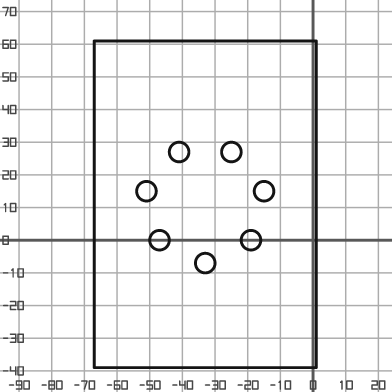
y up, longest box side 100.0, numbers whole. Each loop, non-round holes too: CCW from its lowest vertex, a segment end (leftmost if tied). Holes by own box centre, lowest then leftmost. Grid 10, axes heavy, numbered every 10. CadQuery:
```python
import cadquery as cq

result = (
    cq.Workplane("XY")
    .moveTo(-67.0, -39.0)
    .lineTo(1.0, -39.0)
    .lineTo(1.0, 61.0)
    .lineTo(-67.0, 61.0)
    .close()
    .moveTo(-33.0, -7.0)
    .circle(3.0)
    .moveTo(-47.0, 0.0)
    .circle(3.0)
    .moveTo(-19.0, 0.0)
    .circle(3.0)
    .moveTo(-51.0, 15.0)
    .circle(3.0)
    .moveTo(-15.0, 15.0)
    .circle(3.0)
    .moveTo(-41.0, 27.0)
    .circle(3.0)
    .moveTo(-25.0, 27.0)
    .circle(3.0)
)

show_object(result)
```